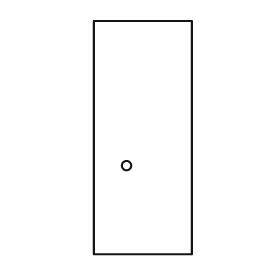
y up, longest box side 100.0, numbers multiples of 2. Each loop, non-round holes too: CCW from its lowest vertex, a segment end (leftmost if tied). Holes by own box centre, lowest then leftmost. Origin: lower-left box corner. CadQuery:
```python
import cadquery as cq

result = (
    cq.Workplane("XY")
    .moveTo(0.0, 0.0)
    .lineTo(42.0, 0.0)
    .lineTo(42.0, 100.0)
    .lineTo(0.0, 100.0)
    .close()
    .moveTo(14.0, 38.0)
    .circle(2.0)
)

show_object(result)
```